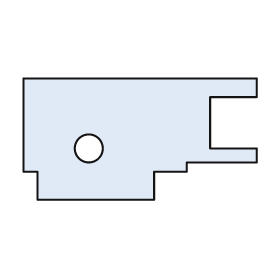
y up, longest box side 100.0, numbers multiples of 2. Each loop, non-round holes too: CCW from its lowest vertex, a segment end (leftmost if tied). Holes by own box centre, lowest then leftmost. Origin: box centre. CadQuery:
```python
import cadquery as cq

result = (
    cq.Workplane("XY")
    .moveTo(-44.0, -26.0)
    .lineTo(6.0, -26.0)
    .lineTo(6.0, -14.0)
    .lineTo(20.0, -14.0)
    .lineTo(20.0, -10.0)
    .lineTo(50.0, -10.0)
    .lineTo(50.0, -4.0)
    .lineTo(30.0, -4.0)
    .lineTo(30.0, 18.0)
    .lineTo(50.0, 18.0)
    .lineTo(50.0, 26.0)
    .lineTo(-50.0, 26.0)
    .lineTo(-50.0, -14.0)
    .lineTo(-44.0, -14.0)
    .close()
    .moveTo(-22.0, -4.0)
    .circle(6.0)
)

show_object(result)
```